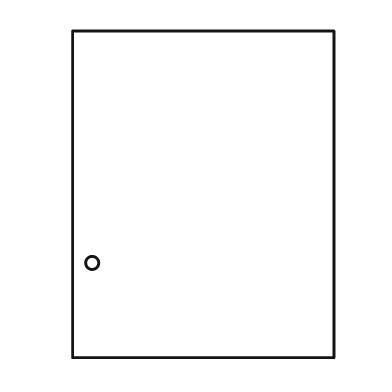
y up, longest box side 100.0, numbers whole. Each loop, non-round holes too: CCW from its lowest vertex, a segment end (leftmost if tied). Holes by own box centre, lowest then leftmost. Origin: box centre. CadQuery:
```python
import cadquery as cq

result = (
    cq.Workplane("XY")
    .moveTo(-40.0, -50.0)
    .lineTo(40.0, -50.0)
    .lineTo(40.0, 50.0)
    .lineTo(-40.0, 50.0)
    .close()
    .moveTo(-34.0, -21.0)
    .circle(2.0)
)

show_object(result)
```